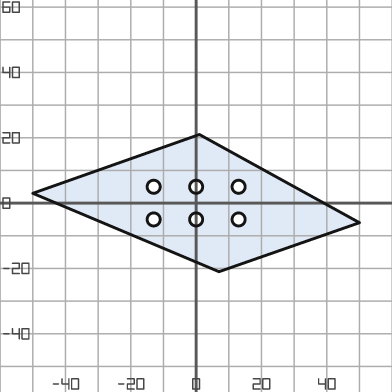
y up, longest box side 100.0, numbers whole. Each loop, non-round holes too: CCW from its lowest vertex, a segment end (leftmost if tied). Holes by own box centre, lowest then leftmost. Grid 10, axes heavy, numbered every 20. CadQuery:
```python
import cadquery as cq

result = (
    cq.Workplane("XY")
    .moveTo(7.0, -21.0)
    .lineTo(50.0, -6.0)
    .lineTo(1.0, 21.0)
    .lineTo(-50.0, 3.0)
    .close()
    .moveTo(-13.0, -5.0)
    .circle(2.0)
    .moveTo(0.0, -5.0)
    .circle(2.0)
    .moveTo(13.0, -5.0)
    .circle(2.0)
    .moveTo(-13.0, 5.0)
    .circle(2.0)
    .moveTo(0.0, 5.0)
    .circle(2.0)
    .moveTo(13.0, 5.0)
    .circle(2.0)
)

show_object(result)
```